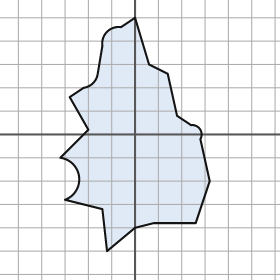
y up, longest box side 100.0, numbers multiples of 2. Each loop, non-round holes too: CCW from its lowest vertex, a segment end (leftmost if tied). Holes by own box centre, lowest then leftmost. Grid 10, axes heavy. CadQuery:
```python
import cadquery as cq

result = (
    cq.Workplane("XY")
    .moveTo(-12.0, -50.0)
    .lineTo(0.0, -40.0)
    .lineTo(8.0, -38.0)
    .lineTo(26.0, -38.0)
    .lineTo(32.0, -20.0)
    .lineTo(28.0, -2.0)
    .threePointArc((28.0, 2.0), (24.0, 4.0))
    .lineTo(18.0, 8.0)
    .lineTo(14.0, 26.0)
    .lineTo(6.0, 30.0)
    .lineTo(0.0, 50.0)
    .lineTo(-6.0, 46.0)
    .threePointArc((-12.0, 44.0), (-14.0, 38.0))
    .lineTo(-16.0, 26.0)
    .threePointArc((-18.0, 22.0), (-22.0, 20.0))
    .lineTo(-28.0, 16.0)
    .lineTo(-20.0, 2.0)
    .lineTo(-32.0, -10.0)
    .threePointArc((-24.0, -18.0), (-30.0, -28.0))
    .lineTo(-14.0, -32.0)
    .close()
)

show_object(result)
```